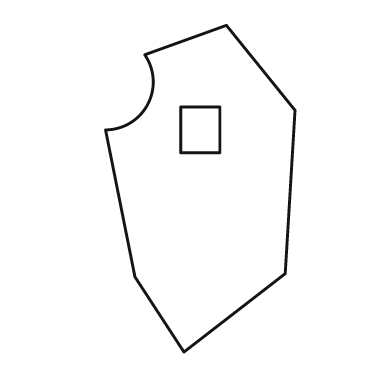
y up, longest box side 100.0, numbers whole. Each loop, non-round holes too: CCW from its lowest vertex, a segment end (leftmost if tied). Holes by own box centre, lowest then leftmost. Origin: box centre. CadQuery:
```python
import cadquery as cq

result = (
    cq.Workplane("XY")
    .moveTo(-5.0, -50.0)
    .lineTo(26.0, -26.0)
    .lineTo(29.0, 24.0)
    .lineTo(8.0, 50.0)
    .lineTo(-17.0, 41.0)
    .threePointArc((-16.0, 26.0), (-29.0, 18.0))
    .lineTo(-20.0, -27.0)
    .close()
    .moveTo(-6.0, 11.0)
    .lineTo(6.0, 11.0)
    .lineTo(6.0, 25.0)
    .lineTo(-6.0, 25.0)
    .close()
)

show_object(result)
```